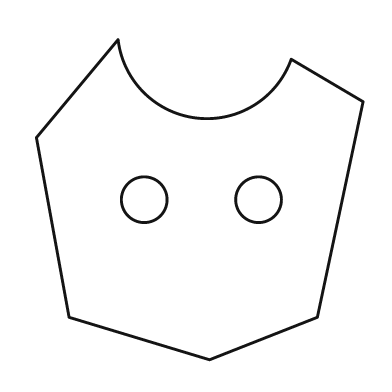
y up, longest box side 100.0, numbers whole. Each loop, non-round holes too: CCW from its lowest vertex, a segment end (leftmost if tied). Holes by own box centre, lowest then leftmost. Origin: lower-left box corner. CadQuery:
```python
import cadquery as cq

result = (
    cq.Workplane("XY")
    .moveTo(53.0, 0.0)
    .lineTo(86.0, 13.0)
    .lineTo(100.0, 79.0)
    .lineTo(78.0, 92.0)
    .threePointArc((49.0, 74.0), (25.0, 98.0))
    .lineTo(0.0, 68.0)
    .lineTo(10.0, 13.0)
    .close()
    .moveTo(33.0, 49.0)
    .circle(7.0)
    .moveTo(68.0, 49.0)
    .circle(7.0)
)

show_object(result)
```